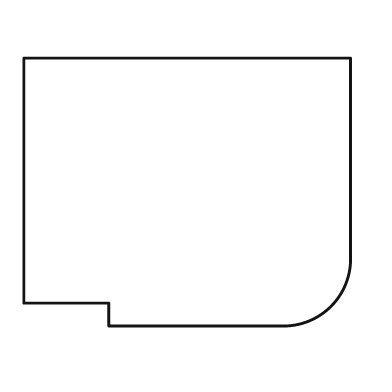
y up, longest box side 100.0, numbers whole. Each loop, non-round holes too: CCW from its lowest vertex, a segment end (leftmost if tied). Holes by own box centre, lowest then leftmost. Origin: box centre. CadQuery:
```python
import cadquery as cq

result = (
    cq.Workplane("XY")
    .moveTo(-24.0, -41.0)
    .lineTo(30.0, -41.0)
    .threePointArc((44.0, -35.0), (50.0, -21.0))
    .lineTo(50.0, 41.0)
    .lineTo(-50.0, 41.0)
    .lineTo(-50.0, -34.0)
    .lineTo(-24.0, -34.0)
    .close()
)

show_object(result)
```